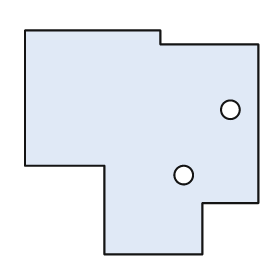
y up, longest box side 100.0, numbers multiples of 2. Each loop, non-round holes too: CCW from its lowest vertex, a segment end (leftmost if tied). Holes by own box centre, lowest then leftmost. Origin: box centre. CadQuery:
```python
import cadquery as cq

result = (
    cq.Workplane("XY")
    .moveTo(-16.0, -48.0)
    .lineTo(26.0, -48.0)
    .lineTo(26.0, -26.0)
    .lineTo(50.0, -26.0)
    .lineTo(50.0, 42.0)
    .lineTo(8.0, 42.0)
    .lineTo(8.0, 48.0)
    .lineTo(-50.0, 48.0)
    .lineTo(-50.0, -10.0)
    .lineTo(-16.0, -10.0)
    .close()
    .moveTo(18.0, -14.0)
    .circle(4.0)
    .moveTo(38.0, 14.0)
    .circle(4.0)
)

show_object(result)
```